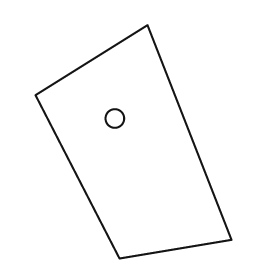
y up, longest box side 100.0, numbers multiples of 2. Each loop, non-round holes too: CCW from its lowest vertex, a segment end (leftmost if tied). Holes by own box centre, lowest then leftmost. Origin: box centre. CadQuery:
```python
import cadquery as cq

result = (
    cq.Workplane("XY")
    .moveTo(-6.0, -50.0)
    .lineTo(42.0, -42.0)
    .lineTo(6.0, 50.0)
    .lineTo(-42.0, 20.0)
    .close()
    .moveTo(-8.0, 10.0)
    .circle(4.0)
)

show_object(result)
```